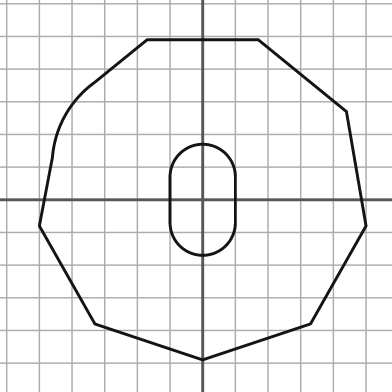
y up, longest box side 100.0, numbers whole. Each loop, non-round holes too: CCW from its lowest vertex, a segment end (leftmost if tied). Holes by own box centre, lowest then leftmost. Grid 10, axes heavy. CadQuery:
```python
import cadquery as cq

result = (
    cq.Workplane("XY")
    .moveTo(0.0, -49.0)
    .lineTo(33.0, -38.0)
    .lineTo(50.0, -8.0)
    .lineTo(44.0, 27.0)
    .lineTo(17.0, 49.0)
    .lineTo(-17.0, 49.0)
    .lineTo(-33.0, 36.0)
    .threePointArc((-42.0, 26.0), (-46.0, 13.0))
    .lineTo(-50.0, -8.0)
    .lineTo(-33.0, -38.0)
    .close()
    .moveTo(-10.0, -7.0)
    .threePointArc((0.0, -17.0), (10.0, -7.0))
    .lineTo(10.0, 7.0)
    .threePointArc((0.0, 17.0), (-10.0, 7.0))
    .close()
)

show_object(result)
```